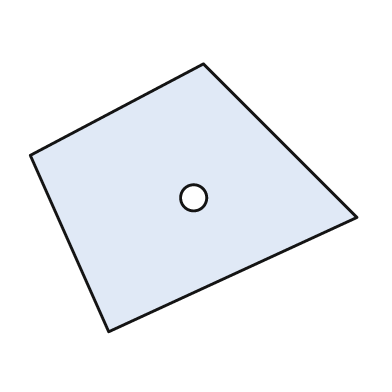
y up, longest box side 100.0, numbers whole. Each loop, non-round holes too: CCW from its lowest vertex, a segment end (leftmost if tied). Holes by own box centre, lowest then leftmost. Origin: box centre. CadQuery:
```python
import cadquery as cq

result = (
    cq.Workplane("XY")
    .moveTo(-26.0, -41.0)
    .lineTo(50.0, -6.0)
    .lineTo(3.0, 41.0)
    .lineTo(-50.0, 13.0)
    .close()
    .moveTo(0.0, 0.0)
    .circle(4.0)
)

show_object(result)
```